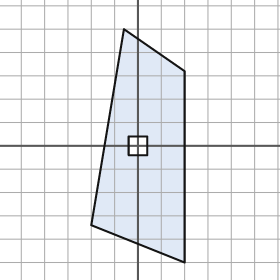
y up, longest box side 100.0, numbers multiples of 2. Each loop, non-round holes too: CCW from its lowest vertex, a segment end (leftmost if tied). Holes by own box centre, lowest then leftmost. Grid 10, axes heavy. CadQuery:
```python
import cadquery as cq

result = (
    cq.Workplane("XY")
    .moveTo(20.0, -50.0)
    .lineTo(20.0, 32.0)
    .lineTo(-6.0, 50.0)
    .lineTo(-20.0, -34.0)
    .close()
    .moveTo(-4.0, -4.0)
    .lineTo(4.0, -4.0)
    .lineTo(4.0, 4.0)
    .lineTo(-4.0, 4.0)
    .close()
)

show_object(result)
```